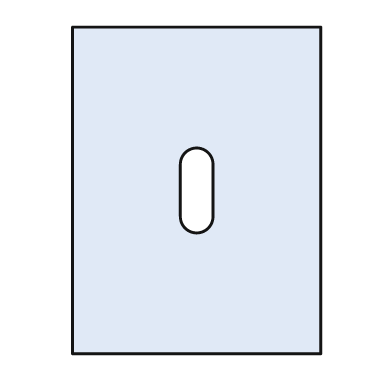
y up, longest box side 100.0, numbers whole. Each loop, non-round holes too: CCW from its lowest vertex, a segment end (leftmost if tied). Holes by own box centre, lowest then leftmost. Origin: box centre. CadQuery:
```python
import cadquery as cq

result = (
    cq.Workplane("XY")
    .moveTo(-38.0, -50.0)
    .lineTo(38.0, -50.0)
    .lineTo(38.0, 50.0)
    .lineTo(-38.0, 50.0)
    .close()
    .moveTo(-5.0, -8.0)
    .threePointArc((0.0, -13.0), (5.0, -8.0))
    .lineTo(5.0, 8.0)
    .threePointArc((0.0, 13.0), (-5.0, 8.0))
    .close()
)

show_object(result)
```